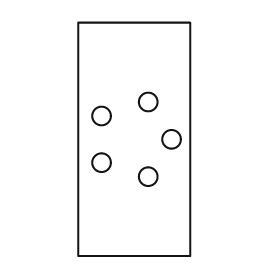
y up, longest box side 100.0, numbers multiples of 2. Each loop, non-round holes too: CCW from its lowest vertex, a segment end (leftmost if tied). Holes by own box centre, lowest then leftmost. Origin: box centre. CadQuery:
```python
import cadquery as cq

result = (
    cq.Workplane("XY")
    .moveTo(-24.0, -50.0)
    .lineTo(24.0, -50.0)
    .lineTo(24.0, 50.0)
    .lineTo(-24.0, 50.0)
    .close()
    .moveTo(6.0, -16.0)
    .circle(4.0)
    .moveTo(-14.0, -10.0)
    .circle(4.0)
    .moveTo(16.0, 0.0)
    .circle(4.0)
    .moveTo(-14.0, 10.0)
    .circle(4.0)
    .moveTo(6.0, 16.0)
    .circle(4.0)
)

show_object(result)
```